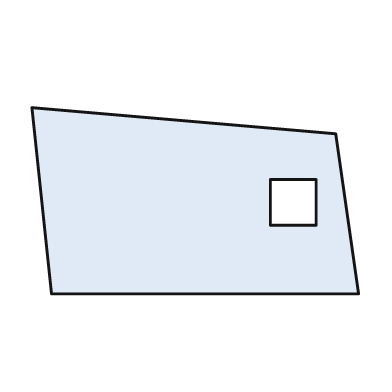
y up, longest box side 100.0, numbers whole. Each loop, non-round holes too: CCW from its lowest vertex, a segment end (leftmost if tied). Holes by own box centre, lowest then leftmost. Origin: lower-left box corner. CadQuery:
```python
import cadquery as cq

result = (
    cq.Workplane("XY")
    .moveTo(6.0, 0.0)
    .lineTo(100.0, 0.0)
    .lineTo(93.0, 49.0)
    .lineTo(0.0, 57.0)
    .close()
    .moveTo(73.0, 21.0)
    .lineTo(87.0, 21.0)
    .lineTo(87.0, 35.0)
    .lineTo(73.0, 35.0)
    .close()
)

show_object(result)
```